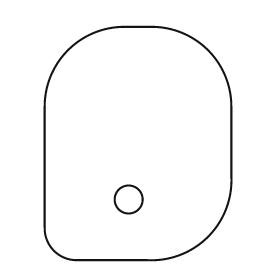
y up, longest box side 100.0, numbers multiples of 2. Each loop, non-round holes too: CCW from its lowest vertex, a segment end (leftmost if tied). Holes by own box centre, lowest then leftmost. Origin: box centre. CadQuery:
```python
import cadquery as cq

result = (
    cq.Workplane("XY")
    .moveTo(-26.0, -50.0)
    .lineTo(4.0, -50.0)
    .threePointArc((30.0, -40.0), (40.0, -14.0))
    .lineTo(40.0, 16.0)
    .threePointArc((30.0, 40.0), (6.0, 50.0))
    .lineTo(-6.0, 50.0)
    .threePointArc((-30.0, 40.0), (-40.0, 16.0))
    .lineTo(-40.0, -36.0)
    .threePointArc((-36.0, -46.0), (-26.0, -50.0))
    .close()
    .moveTo(-4.0, -24.0)
    .circle(6.0)
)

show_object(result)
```